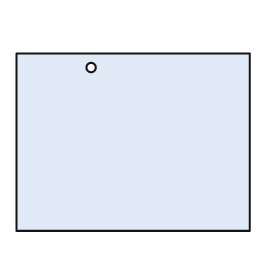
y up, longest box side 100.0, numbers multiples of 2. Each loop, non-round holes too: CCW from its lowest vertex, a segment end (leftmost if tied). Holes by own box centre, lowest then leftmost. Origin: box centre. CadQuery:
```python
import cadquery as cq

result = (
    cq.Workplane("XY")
    .moveTo(-50.0, -38.0)
    .lineTo(50.0, -38.0)
    .lineTo(50.0, 38.0)
    .lineTo(-50.0, 38.0)
    .close()
    .moveTo(-18.0, 32.0)
    .circle(2.0)
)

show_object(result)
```